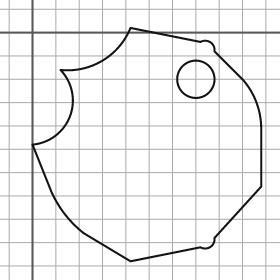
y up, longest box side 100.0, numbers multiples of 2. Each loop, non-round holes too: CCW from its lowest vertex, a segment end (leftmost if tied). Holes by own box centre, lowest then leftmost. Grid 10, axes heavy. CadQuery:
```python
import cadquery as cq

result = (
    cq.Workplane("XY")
    .moveTo(42.0, -98.0)
    .lineTo(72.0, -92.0)
    .threePointArc((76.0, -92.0), (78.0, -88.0))
    .lineTo(98.0, -66.0)
    .lineTo(98.0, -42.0)
    .threePointArc((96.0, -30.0), (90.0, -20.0))
    .lineTo(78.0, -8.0)
    .threePointArc((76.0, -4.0), (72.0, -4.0))
    .lineTo(42.0, 2.0)
    .threePointArc((30.0, -12.0), (12.0, -16.0))
    .threePointArc((16.0, -36.0), (0.0, -48.0))
    .lineTo(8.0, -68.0)
    .threePointArc((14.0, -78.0), (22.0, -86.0))
    .close()
    .moveTo(70.0, -20.0)
    .circle(8.0)
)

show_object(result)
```